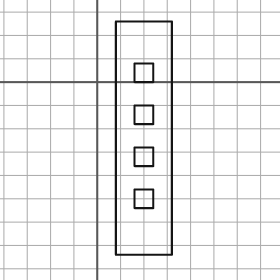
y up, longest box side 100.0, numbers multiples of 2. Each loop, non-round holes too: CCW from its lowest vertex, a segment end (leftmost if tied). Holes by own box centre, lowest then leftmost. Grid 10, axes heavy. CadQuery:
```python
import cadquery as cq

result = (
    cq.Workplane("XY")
    .moveTo(8.0, -74.0)
    .lineTo(32.0, -74.0)
    .lineTo(32.0, 26.0)
    .lineTo(8.0, 26.0)
    .close()
    .moveTo(16.0, -54.0)
    .lineTo(24.0, -54.0)
    .lineTo(24.0, -46.0)
    .lineTo(16.0, -46.0)
    .close()
    .moveTo(16.0, -36.0)
    .lineTo(24.0, -36.0)
    .lineTo(24.0, -28.0)
    .lineTo(16.0, -28.0)
    .close()
    .moveTo(16.0, -18.0)
    .lineTo(24.0, -18.0)
    .lineTo(24.0, -10.0)
    .lineTo(16.0, -10.0)
    .close()
    .moveTo(16.0, 0.0)
    .lineTo(24.0, 0.0)
    .lineTo(24.0, 8.0)
    .lineTo(16.0, 8.0)
    .close()
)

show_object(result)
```